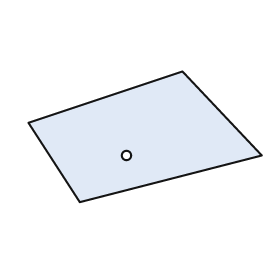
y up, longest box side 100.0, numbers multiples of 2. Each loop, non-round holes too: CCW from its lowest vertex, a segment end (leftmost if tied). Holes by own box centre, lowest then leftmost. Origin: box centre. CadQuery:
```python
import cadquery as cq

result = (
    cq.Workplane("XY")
    .moveTo(-28.0, -28.0)
    .lineTo(50.0, -8.0)
    .lineTo(16.0, 28.0)
    .lineTo(-50.0, 6.0)
    .close()
    .moveTo(-8.0, -8.0)
    .circle(2.0)
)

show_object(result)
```